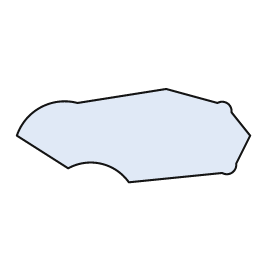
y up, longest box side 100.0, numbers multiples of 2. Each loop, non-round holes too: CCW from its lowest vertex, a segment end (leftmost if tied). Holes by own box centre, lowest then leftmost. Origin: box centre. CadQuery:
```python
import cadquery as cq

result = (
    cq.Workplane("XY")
    .moveTo(-2.0, -20.0)
    .lineTo(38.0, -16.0)
    .threePointArc((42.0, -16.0), (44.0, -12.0))
    .lineTo(50.0, 0.0)
    .lineTo(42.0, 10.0)
    .threePointArc((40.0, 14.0), (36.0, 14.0))
    .lineTo(14.0, 20.0)
    .lineTo(-24.0, 14.0)
    .threePointArc((-40.0, 12.0), (-50.0, 0.0))
    .lineTo(-28.0, -14.0)
    .threePointArc((-14.0, -12.0), (-2.0, -20.0))
    .close()
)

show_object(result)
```